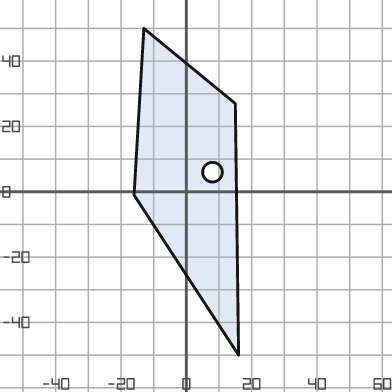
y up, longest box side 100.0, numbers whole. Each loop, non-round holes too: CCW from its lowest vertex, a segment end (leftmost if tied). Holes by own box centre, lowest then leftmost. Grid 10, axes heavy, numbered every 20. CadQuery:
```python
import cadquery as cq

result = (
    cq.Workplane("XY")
    .moveTo(16.0, -50.0)
    .lineTo(15.0, 27.0)
    .lineTo(-13.0, 50.0)
    .lineTo(-16.0, -1.0)
    .close()
    .moveTo(8.0, 6.0)
    .circle(3.0)
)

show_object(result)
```